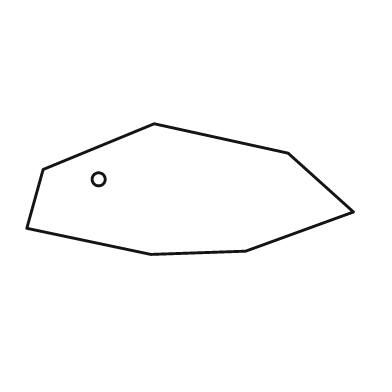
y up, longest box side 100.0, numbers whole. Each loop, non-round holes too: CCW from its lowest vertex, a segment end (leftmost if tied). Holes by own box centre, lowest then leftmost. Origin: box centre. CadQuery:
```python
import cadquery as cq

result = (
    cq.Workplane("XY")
    .moveTo(-12.0, -20.0)
    .lineTo(17.0, -19.0)
    .lineTo(50.0, -7.0)
    .lineTo(30.0, 11.0)
    .lineTo(-11.0, 20.0)
    .lineTo(-45.0, 6.0)
    .lineTo(-50.0, -12.0)
    .close()
    .moveTo(-28.0, 3.0)
    .circle(2.0)
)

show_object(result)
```